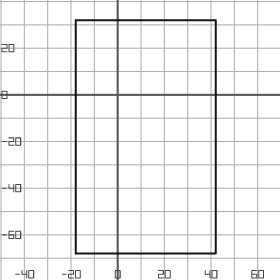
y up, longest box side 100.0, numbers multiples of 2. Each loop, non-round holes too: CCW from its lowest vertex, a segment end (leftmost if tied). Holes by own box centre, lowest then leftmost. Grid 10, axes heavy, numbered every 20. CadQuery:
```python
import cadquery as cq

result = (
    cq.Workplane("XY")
    .moveTo(-18.0, -68.0)
    .lineTo(42.0, -68.0)
    .lineTo(42.0, 32.0)
    .lineTo(-18.0, 32.0)
    .close()
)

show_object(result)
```